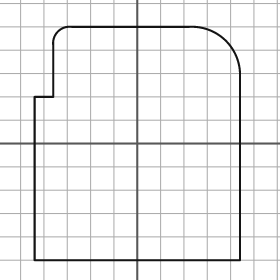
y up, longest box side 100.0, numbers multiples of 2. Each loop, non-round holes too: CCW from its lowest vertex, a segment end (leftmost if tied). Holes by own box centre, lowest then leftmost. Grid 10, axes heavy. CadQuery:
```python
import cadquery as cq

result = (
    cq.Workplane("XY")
    .moveTo(-44.0, -50.0)
    .lineTo(44.0, -50.0)
    .lineTo(44.0, 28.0)
    .threePointArc((38.0, 44.0), (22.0, 50.0))
    .lineTo(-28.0, 50.0)
    .threePointArc((-34.0, 48.0), (-36.0, 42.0))
    .lineTo(-36.0, 20.0)
    .lineTo(-44.0, 20.0)
    .close()
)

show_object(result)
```